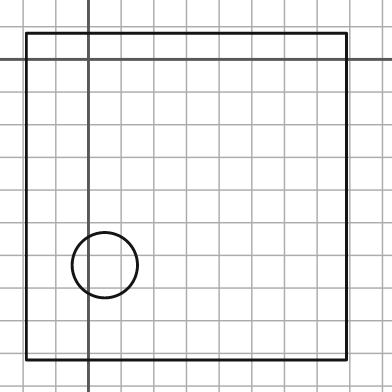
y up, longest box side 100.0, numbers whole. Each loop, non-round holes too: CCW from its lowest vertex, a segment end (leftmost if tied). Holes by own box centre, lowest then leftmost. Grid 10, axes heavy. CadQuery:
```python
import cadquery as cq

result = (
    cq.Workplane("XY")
    .moveTo(-19.0, -92.0)
    .lineTo(79.0, -92.0)
    .lineTo(79.0, 8.0)
    .lineTo(-19.0, 8.0)
    .close()
    .moveTo(5.0, -63.0)
    .circle(10.0)
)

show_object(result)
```